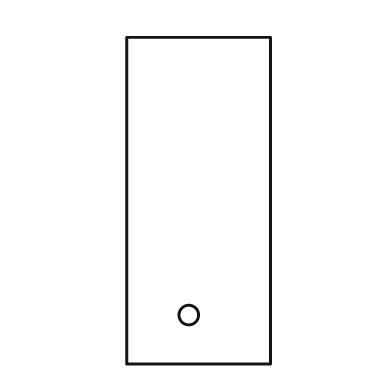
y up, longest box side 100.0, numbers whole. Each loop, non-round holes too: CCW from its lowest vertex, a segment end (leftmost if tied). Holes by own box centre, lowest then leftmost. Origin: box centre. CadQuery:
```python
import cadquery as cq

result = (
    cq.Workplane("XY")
    .moveTo(-22.0, -50.0)
    .lineTo(22.0, -50.0)
    .lineTo(22.0, 50.0)
    .lineTo(-22.0, 50.0)
    .close()
    .moveTo(-3.0, -35.0)
    .circle(3.0)
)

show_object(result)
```